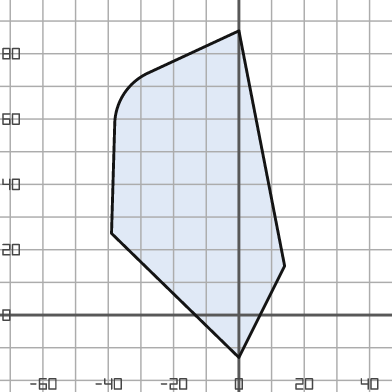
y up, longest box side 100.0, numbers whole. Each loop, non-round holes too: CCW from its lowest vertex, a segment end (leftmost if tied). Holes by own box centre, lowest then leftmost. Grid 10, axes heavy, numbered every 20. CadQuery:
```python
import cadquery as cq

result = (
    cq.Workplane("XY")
    .moveTo(0.0, -13.0)
    .lineTo(14.0, 15.0)
    .lineTo(0.0, 87.0)
    .lineTo(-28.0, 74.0)
    .threePointArc((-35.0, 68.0), (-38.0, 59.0))
    .lineTo(-39.0, 25.0)
    .close()
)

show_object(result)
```